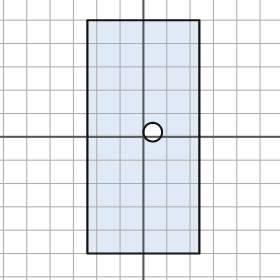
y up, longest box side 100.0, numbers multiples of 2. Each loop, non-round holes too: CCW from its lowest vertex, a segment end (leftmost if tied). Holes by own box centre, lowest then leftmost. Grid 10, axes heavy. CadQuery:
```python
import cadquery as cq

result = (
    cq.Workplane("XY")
    .moveTo(-24.0, -50.0)
    .lineTo(24.0, -50.0)
    .lineTo(24.0, 50.0)
    .lineTo(-24.0, 50.0)
    .close()
    .moveTo(4.0, 2.0)
    .circle(4.0)
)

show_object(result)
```